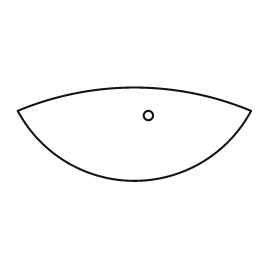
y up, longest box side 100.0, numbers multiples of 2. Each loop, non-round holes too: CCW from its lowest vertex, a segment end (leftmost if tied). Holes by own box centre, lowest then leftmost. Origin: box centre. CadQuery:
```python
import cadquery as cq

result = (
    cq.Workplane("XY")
    .moveTo(-50.0, 10.0)
    .threePointArc((0.0, -20.0), (50.0, 10.0))
    .threePointArc((0.0, 20.0), (-50.0, 10.0))
    .close()
    .moveTo(6.0, 8.0)
    .circle(2.0)
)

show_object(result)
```